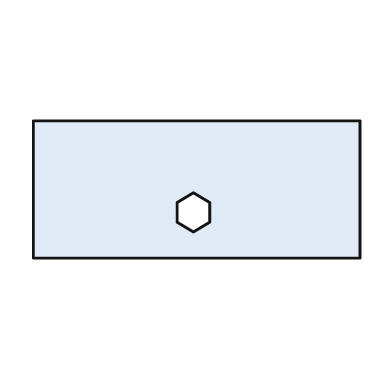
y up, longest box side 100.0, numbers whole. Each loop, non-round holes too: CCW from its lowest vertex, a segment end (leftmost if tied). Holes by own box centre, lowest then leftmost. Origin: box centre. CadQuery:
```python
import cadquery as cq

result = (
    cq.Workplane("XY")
    .moveTo(-50.0, -21.0)
    .lineTo(50.0, -21.0)
    .lineTo(50.0, 21.0)
    .lineTo(-50.0, 21.0)
    .close()
    .moveTo(-1.0, -13.0)
    .lineTo(4.0, -10.0)
    .lineTo(4.0, -4.0)
    .lineTo(-1.0, -1.0)
    .lineTo(-6.0, -4.0)
    .lineTo(-6.0, -10.0)
    .close()
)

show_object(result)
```